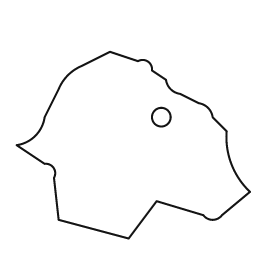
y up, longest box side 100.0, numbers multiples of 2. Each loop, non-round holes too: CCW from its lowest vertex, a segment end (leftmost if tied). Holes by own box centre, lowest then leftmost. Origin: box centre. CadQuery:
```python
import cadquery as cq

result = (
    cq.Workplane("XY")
    .moveTo(-2.0, -40.0)
    .lineTo(10.0, -24.0)
    .lineTo(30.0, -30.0)
    .threePointArc((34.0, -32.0), (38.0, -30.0))
    .lineTo(50.0, -20.0)
    .threePointArc((42.0, -8.0), (40.0, 6.0))
    .lineTo(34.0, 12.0)
    .threePointArc((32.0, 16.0), (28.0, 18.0))
    .lineTo(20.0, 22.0)
    .threePointArc((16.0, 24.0), (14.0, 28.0))
    .lineTo(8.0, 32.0)
    .threePointArc((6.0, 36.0), (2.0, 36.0))
    .lineTo(-10.0, 40.0)
    .lineTo(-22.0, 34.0)
    .threePointArc((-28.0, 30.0), (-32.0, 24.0))
    .lineTo(-38.0, 12.0)
    .threePointArc((-42.0, 4.0), (-50.0, 0.0))
    .lineTo(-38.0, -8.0)
    .threePointArc((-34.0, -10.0), (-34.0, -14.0))
    .lineTo(-32.0, -32.0)
    .close()
    .moveTo(12.0, 12.0)
    .circle(4.0)
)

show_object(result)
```